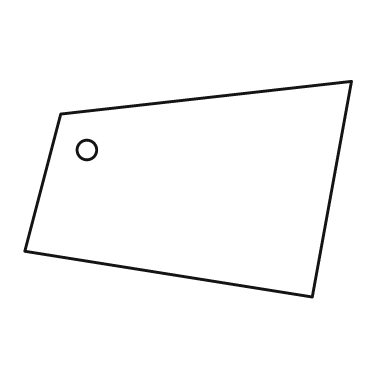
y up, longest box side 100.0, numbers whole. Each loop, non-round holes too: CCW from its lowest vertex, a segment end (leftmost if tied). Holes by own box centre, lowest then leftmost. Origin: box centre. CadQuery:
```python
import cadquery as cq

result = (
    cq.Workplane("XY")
    .moveTo(38.0, -33.0)
    .lineTo(50.0, 33.0)
    .lineTo(-39.0, 23.0)
    .lineTo(-50.0, -19.0)
    .close()
    .moveTo(-31.0, 12.0)
    .circle(3.0)
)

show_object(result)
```